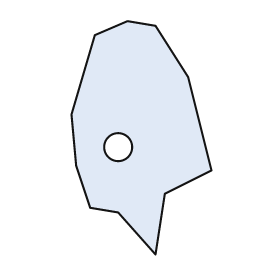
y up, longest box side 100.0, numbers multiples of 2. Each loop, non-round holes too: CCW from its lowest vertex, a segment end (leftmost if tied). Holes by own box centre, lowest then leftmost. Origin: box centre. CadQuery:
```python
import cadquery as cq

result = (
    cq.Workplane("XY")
    .moveTo(6.0, -50.0)
    .lineTo(10.0, -24.0)
    .lineTo(30.0, -14.0)
    .lineTo(20.0, 26.0)
    .lineTo(6.0, 48.0)
    .lineTo(-6.0, 50.0)
    .lineTo(-20.0, 44.0)
    .lineTo(-30.0, 10.0)
    .lineTo(-28.0, -12.0)
    .lineTo(-22.0, -30.0)
    .lineTo(-10.0, -32.0)
    .close()
    .moveTo(-10.0, -4.0)
    .circle(6.0)
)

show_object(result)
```